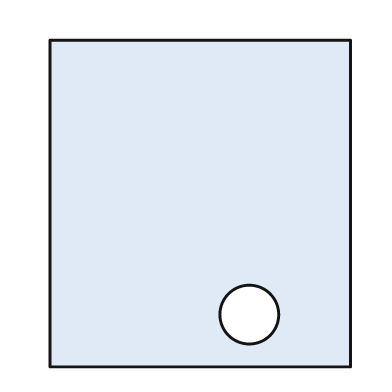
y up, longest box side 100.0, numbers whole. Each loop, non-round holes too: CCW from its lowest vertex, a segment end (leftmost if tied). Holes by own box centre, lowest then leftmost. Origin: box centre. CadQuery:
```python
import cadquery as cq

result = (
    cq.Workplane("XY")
    .moveTo(-46.0, -50.0)
    .lineTo(46.0, -50.0)
    .lineTo(46.0, 50.0)
    .lineTo(-46.0, 50.0)
    .close()
    .moveTo(15.0, -34.0)
    .circle(9.0)
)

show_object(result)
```